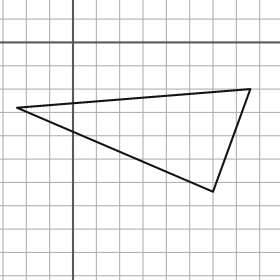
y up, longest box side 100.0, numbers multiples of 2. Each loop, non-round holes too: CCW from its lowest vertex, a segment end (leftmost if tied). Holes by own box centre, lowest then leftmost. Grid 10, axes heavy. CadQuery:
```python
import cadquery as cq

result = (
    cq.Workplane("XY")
    .moveTo(60.0, -64.0)
    .lineTo(76.0, -20.0)
    .lineTo(-24.0, -28.0)
    .close()
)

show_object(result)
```